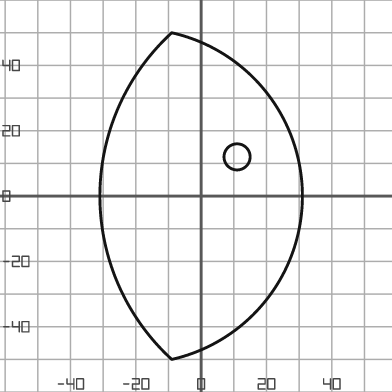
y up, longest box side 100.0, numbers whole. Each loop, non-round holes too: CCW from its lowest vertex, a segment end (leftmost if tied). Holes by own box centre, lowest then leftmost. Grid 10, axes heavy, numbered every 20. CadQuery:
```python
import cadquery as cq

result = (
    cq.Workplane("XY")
    .moveTo(-9.0, -50.0)
    .threePointArc((31.0, 0.0), (-9.0, 50.0))
    .threePointArc((-31.0, 0.0), (-9.0, -50.0))
    .close()
    .moveTo(11.0, 12.0)
    .circle(4.0)
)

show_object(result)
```